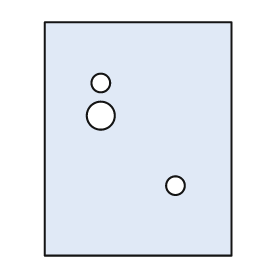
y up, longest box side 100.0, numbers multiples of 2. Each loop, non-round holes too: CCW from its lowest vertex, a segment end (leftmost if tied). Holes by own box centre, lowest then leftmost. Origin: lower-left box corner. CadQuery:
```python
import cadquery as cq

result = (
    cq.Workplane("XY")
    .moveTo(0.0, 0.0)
    .lineTo(80.0, 0.0)
    .lineTo(80.0, 100.0)
    .lineTo(0.0, 100.0)
    .close()
    .moveTo(56.0, 30.0)
    .circle(4.0)
    .moveTo(24.0, 60.0)
    .circle(6.0)
    .moveTo(24.0, 74.0)
    .circle(4.0)
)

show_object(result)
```